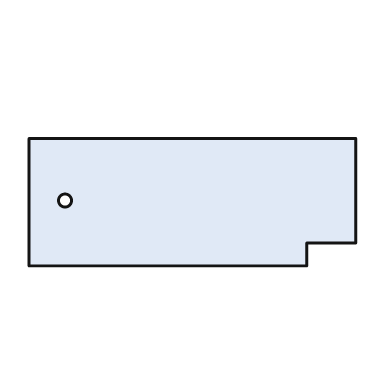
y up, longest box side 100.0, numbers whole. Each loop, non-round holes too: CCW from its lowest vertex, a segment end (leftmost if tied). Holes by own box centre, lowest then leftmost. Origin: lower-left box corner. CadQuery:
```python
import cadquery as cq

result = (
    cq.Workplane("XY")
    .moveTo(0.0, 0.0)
    .lineTo(85.0, 0.0)
    .lineTo(85.0, 7.0)
    .lineTo(100.0, 7.0)
    .lineTo(100.0, 39.0)
    .lineTo(0.0, 39.0)
    .close()
    .moveTo(11.0, 20.0)
    .circle(2.0)
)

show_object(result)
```